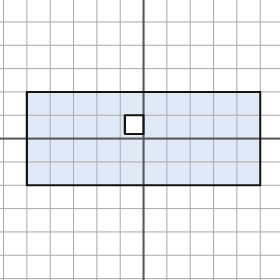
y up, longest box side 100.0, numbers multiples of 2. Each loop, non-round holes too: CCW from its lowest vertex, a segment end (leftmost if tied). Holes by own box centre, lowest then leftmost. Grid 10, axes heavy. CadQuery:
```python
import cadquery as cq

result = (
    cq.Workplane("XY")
    .moveTo(-50.0, -20.0)
    .lineTo(50.0, -20.0)
    .lineTo(50.0, 20.0)
    .lineTo(-50.0, 20.0)
    .close()
    .moveTo(-8.0, 2.0)
    .lineTo(0.0, 2.0)
    .lineTo(0.0, 10.0)
    .lineTo(-8.0, 10.0)
    .close()
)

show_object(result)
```